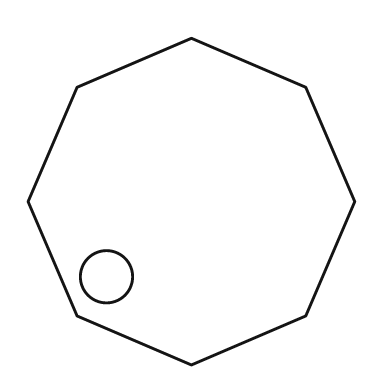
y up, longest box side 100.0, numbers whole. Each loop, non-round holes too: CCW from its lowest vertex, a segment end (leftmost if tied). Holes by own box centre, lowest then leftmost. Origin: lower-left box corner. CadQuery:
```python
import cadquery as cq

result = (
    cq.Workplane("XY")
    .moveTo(50.0, 0.0)
    .lineTo(85.0, 15.0)
    .lineTo(100.0, 50.0)
    .lineTo(85.0, 85.0)
    .lineTo(50.0, 100.0)
    .lineTo(15.0, 85.0)
    .lineTo(0.0, 50.0)
    .lineTo(15.0, 15.0)
    .close()
    .moveTo(24.0, 27.0)
    .circle(8.0)
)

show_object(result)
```